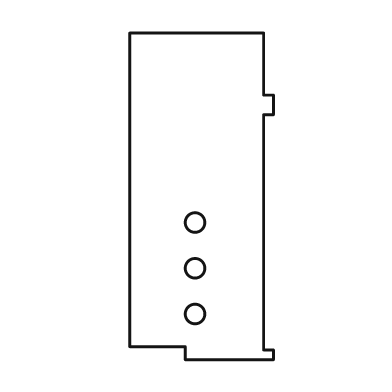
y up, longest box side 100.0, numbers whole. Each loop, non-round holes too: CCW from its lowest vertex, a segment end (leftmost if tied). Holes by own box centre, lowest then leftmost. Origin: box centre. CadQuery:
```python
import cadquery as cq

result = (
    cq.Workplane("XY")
    .moveTo(-5.0, -50.0)
    .lineTo(22.0, -50.0)
    .lineTo(22.0, -47.0)
    .lineTo(19.0, -47.0)
    .lineTo(19.0, 25.0)
    .lineTo(22.0, 25.0)
    .lineTo(22.0, 31.0)
    .lineTo(19.0, 31.0)
    .lineTo(19.0, 50.0)
    .lineTo(-22.0, 50.0)
    .lineTo(-22.0, -46.0)
    .lineTo(-5.0, -46.0)
    .close()
    .moveTo(-2.0, -36.0)
    .circle(3.0)
    .moveTo(-2.0, -22.0)
    .circle(3.0)
    .moveTo(-2.0, -8.0)
    .circle(3.0)
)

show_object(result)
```